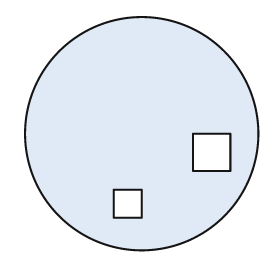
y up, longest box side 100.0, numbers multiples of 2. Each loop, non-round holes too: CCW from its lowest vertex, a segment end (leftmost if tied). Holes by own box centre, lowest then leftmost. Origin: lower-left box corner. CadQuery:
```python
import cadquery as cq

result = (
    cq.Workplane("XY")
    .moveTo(50.0, 50.0)
    .circle(50.0)
    .moveTo(38.0, 14.0)
    .lineTo(50.0, 14.0)
    .lineTo(50.0, 26.0)
    .lineTo(38.0, 26.0)
    .close()
    .moveTo(72.0, 34.0)
    .lineTo(88.0, 34.0)
    .lineTo(88.0, 50.0)
    .lineTo(72.0, 50.0)
    .close()
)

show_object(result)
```